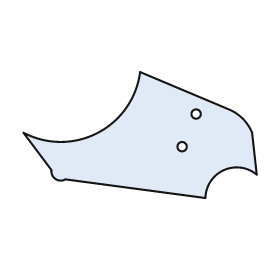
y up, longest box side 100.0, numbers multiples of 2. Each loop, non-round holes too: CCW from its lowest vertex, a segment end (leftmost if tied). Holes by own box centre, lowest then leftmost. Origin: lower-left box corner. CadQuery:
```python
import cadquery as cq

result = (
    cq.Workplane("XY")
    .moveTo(78.0, 0.0)
    .threePointArc((86.0, 12.0), (100.0, 10.0))
    .lineTo(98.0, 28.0)
    .threePointArc((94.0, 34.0), (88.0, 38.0))
    .lineTo(50.0, 54.0)
    .threePointArc((32.0, 28.0), (0.0, 28.0))
    .lineTo(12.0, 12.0)
    .threePointArc((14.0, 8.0), (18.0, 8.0))
    .close()
    .moveTo(68.0, 22.0)
    .circle(2.0)
    .moveTo(74.0, 36.0)
    .circle(2.0)
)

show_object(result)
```